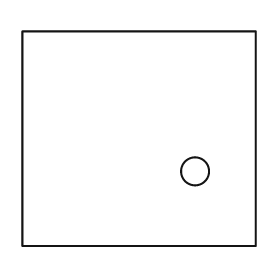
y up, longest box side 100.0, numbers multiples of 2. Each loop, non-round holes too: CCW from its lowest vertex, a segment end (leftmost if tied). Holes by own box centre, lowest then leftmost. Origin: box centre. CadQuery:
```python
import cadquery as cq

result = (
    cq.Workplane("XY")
    .moveTo(-50.0, -46.0)
    .lineTo(50.0, -46.0)
    .lineTo(50.0, 46.0)
    .lineTo(-50.0, 46.0)
    .close()
    .moveTo(24.0, -14.0)
    .circle(6.0)
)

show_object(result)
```